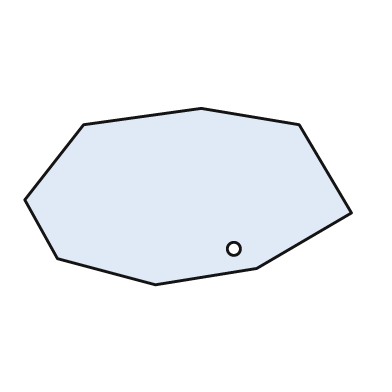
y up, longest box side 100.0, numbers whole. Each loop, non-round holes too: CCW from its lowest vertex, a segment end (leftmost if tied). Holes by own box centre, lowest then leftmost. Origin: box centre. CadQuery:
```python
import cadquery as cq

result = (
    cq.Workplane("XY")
    .moveTo(-10.0, -27.0)
    .lineTo(21.0, -22.0)
    .lineTo(50.0, -5.0)
    .lineTo(34.0, 22.0)
    .lineTo(4.0, 27.0)
    .lineTo(-32.0, 22.0)
    .lineTo(-50.0, -1.0)
    .lineTo(-40.0, -19.0)
    .close()
    .moveTo(14.0, -16.0)
    .circle(2.0)
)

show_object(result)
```